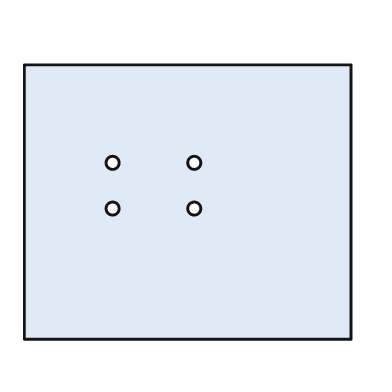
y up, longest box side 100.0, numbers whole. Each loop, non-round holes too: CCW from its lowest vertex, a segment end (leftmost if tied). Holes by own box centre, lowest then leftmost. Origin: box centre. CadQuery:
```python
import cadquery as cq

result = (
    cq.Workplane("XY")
    .moveTo(-50.0, -42.0)
    .lineTo(50.0, -42.0)
    .lineTo(50.0, 42.0)
    .lineTo(-50.0, 42.0)
    .close()
    .moveTo(-23.0, -2.0)
    .circle(2.0)
    .moveTo(2.0, -2.0)
    .circle(2.0)
    .moveTo(-23.0, 12.0)
    .circle(2.0)
    .moveTo(2.0, 12.0)
    .circle(2.0)
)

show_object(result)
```